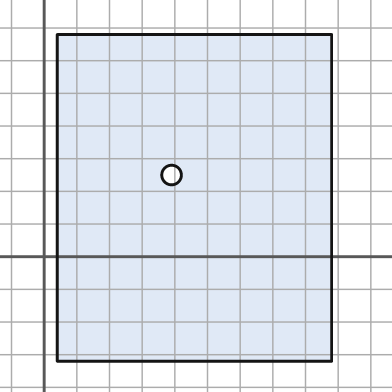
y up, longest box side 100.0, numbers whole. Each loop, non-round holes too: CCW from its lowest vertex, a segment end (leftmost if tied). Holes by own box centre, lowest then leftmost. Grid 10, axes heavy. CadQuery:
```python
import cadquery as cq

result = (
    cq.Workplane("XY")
    .moveTo(4.0, -32.0)
    .lineTo(88.0, -32.0)
    .lineTo(88.0, 68.0)
    .lineTo(4.0, 68.0)
    .close()
    .moveTo(39.0, 25.0)
    .circle(3.0)
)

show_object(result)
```